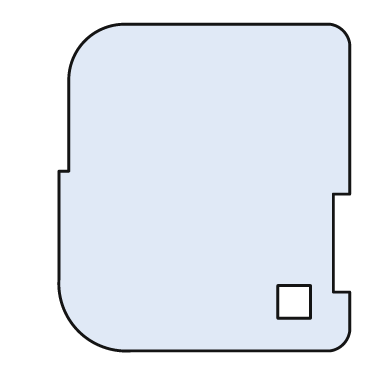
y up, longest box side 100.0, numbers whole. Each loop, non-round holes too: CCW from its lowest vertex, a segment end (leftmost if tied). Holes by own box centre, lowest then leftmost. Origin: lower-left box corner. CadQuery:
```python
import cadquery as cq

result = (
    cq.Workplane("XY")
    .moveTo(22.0, 0.0)
    .lineTo(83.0, 0.0)
    .threePointArc((87.0, 2.0), (89.0, 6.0))
    .lineTo(89.0, 18.0)
    .lineTo(84.0, 18.0)
    .lineTo(84.0, 48.0)
    .lineTo(89.0, 48.0)
    .lineTo(89.0, 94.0)
    .threePointArc((87.0, 98.0), (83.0, 100.0))
    .lineTo(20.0, 100.0)
    .threePointArc((8.0, 95.0), (3.0, 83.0))
    .lineTo(3.0, 55.0)
    .lineTo(0.0, 55.0)
    .lineTo(0.0, 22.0)
    .threePointArc((6.0, 6.0), (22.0, 0.0))
    .close()
    .moveTo(67.0, 10.0)
    .lineTo(77.0, 10.0)
    .lineTo(77.0, 20.0)
    .lineTo(67.0, 20.0)
    .close()
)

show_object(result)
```